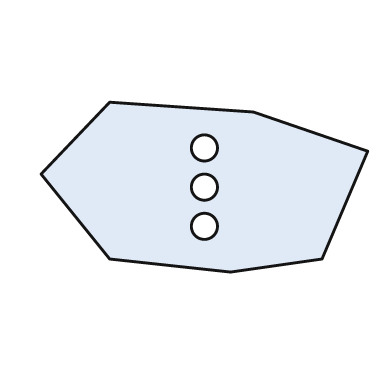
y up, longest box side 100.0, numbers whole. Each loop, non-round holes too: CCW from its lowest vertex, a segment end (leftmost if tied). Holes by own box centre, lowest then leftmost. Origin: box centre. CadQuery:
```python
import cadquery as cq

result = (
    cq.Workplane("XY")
    .moveTo(8.0, -26.0)
    .lineTo(36.0, -22.0)
    .lineTo(50.0, 11.0)
    .lineTo(15.0, 23.0)
    .lineTo(-29.0, 26.0)
    .lineTo(-50.0, 4.0)
    .lineTo(-29.0, -22.0)
    .close()
    .moveTo(0.0, -12.0)
    .circle(4.0)
    .moveTo(0.0, 0.0)
    .circle(4.0)
    .moveTo(0.0, 12.0)
    .circle(4.0)
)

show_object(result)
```